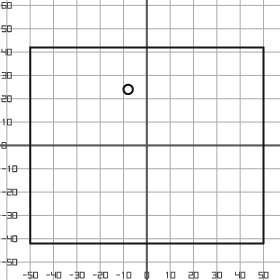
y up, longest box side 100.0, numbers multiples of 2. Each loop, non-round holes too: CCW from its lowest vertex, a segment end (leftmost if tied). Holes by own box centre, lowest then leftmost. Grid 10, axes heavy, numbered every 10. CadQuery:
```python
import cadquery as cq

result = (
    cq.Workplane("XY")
    .moveTo(-50.0, -42.0)
    .lineTo(50.0, -42.0)
    .lineTo(50.0, 42.0)
    .lineTo(-50.0, 42.0)
    .close()
    .moveTo(-8.0, 24.0)
    .circle(2.0)
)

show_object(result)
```